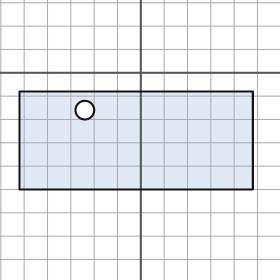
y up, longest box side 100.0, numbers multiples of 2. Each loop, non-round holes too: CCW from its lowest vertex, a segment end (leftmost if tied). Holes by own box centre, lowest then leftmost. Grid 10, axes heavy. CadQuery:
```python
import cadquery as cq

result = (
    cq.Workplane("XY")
    .moveTo(-52.0, -50.0)
    .lineTo(48.0, -50.0)
    .lineTo(48.0, -8.0)
    .lineTo(-52.0, -8.0)
    .close()
    .moveTo(-24.0, -16.0)
    .circle(4.0)
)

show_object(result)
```